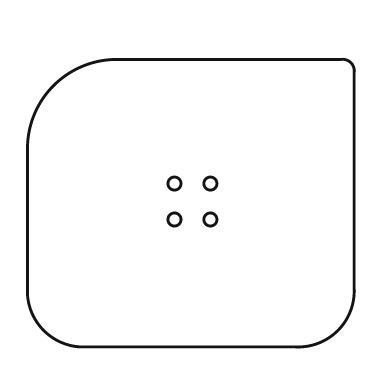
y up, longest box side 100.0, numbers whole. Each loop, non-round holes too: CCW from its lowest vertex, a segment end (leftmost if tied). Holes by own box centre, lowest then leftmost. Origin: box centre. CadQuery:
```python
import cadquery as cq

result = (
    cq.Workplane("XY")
    .moveTo(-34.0, -44.0)
    .lineTo(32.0, -44.0)
    .threePointArc((45.0, -39.0), (50.0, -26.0))
    .lineTo(50.0, 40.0)
    .threePointArc((49.0, 43.0), (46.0, 44.0))
    .lineTo(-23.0, 44.0)
    .threePointArc((-42.0, 36.0), (-50.0, 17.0))
    .lineTo(-50.0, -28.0)
    .threePointArc((-45.0, -39.0), (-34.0, -44.0))
    .close()
    .moveTo(-5.0, -5.0)
    .circle(2.0)
    .moveTo(6.0, -5.0)
    .circle(2.0)
    .moveTo(-5.0, 6.0)
    .circle(2.0)
    .moveTo(6.0, 6.0)
    .circle(2.0)
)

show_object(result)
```